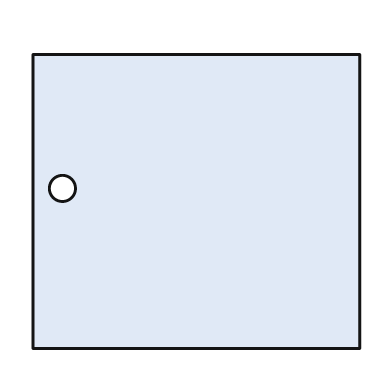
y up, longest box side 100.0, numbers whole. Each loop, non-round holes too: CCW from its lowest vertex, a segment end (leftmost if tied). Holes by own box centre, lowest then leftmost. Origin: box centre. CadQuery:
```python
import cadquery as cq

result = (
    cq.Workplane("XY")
    .moveTo(-50.0, -45.0)
    .lineTo(50.0, -45.0)
    .lineTo(50.0, 45.0)
    .lineTo(-50.0, 45.0)
    .close()
    .moveTo(-41.0, 4.0)
    .circle(4.0)
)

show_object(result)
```